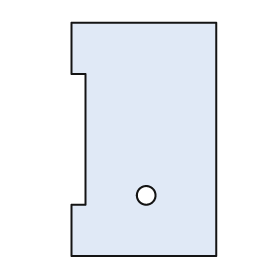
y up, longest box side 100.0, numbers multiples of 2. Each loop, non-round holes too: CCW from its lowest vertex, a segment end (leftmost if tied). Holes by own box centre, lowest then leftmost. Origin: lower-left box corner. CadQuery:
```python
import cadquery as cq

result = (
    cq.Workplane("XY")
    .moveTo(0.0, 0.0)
    .lineTo(62.0, 0.0)
    .lineTo(62.0, 100.0)
    .lineTo(0.0, 100.0)
    .lineTo(0.0, 78.0)
    .lineTo(6.0, 78.0)
    .lineTo(6.0, 22.0)
    .lineTo(0.0, 22.0)
    .close()
    .moveTo(32.0, 26.0)
    .circle(4.0)
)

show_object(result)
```